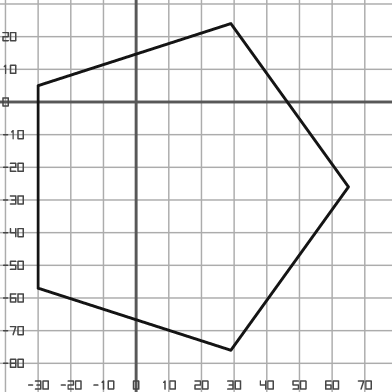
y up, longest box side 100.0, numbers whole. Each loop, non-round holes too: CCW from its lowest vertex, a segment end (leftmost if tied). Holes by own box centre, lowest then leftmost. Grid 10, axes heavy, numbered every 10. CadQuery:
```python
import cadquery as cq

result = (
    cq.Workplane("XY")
    .moveTo(29.0, -76.0)
    .lineTo(65.0, -26.0)
    .lineTo(29.0, 24.0)
    .lineTo(-30.0, 5.0)
    .lineTo(-30.0, -57.0)
    .close()
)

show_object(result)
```